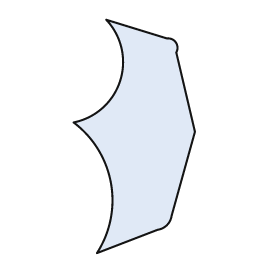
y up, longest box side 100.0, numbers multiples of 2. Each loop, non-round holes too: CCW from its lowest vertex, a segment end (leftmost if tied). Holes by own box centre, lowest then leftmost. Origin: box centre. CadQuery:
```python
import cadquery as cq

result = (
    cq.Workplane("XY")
    .moveTo(-16.0, -50.0)
    .lineTo(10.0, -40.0)
    .threePointArc((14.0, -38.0), (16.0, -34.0))
    .lineTo(26.0, 2.0)
    .lineTo(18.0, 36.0)
    .threePointArc((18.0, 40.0), (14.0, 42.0))
    .lineTo(-12.0, 50.0)
    .threePointArc((-6.0, 24.0), (-26.0, 6.0))
    .threePointArc((-10.0, -20.0), (-16.0, -50.0))
    .close()
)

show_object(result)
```